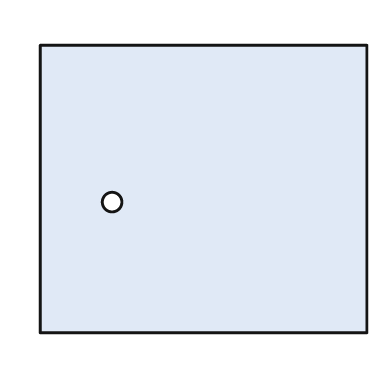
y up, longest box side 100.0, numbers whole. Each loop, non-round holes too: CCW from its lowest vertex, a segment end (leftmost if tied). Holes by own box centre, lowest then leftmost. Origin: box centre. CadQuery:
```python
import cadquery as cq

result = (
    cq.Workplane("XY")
    .moveTo(-50.0, -44.0)
    .lineTo(50.0, -44.0)
    .lineTo(50.0, 44.0)
    .lineTo(-50.0, 44.0)
    .close()
    .moveTo(-28.0, -4.0)
    .circle(3.0)
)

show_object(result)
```